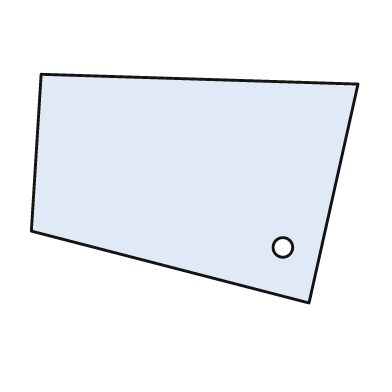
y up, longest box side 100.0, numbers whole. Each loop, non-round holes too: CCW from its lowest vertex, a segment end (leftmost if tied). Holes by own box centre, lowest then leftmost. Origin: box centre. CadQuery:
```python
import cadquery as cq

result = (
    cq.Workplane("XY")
    .moveTo(35.0, -35.0)
    .lineTo(50.0, 32.0)
    .lineTo(-47.0, 35.0)
    .lineTo(-50.0, -13.0)
    .close()
    .moveTo(27.0, -18.0)
    .circle(3.0)
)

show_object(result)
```